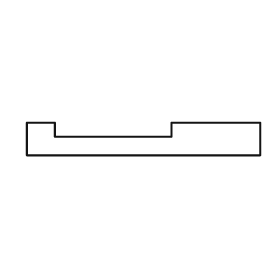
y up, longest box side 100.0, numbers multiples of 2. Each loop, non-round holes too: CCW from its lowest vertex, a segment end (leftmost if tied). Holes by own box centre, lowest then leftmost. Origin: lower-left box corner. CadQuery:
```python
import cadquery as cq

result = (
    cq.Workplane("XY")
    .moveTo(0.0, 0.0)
    .lineTo(100.0, 0.0)
    .lineTo(100.0, 14.0)
    .lineTo(62.0, 14.0)
    .lineTo(62.0, 8.0)
    .lineTo(12.0, 8.0)
    .lineTo(12.0, 14.0)
    .lineTo(0.0, 14.0)
    .close()
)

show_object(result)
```